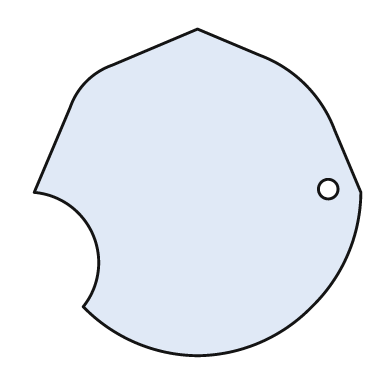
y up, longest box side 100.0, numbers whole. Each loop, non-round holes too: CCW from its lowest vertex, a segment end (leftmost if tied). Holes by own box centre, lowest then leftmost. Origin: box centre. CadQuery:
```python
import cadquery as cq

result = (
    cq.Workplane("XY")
    .moveTo(0.0, -50.0)
    .threePointArc((19.0, -46.0), (35.0, -35.0))
    .threePointArc((46.0, -19.0), (50.0, 0.0))
    .lineTo(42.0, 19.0)
    .threePointArc((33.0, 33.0), (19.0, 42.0))
    .lineTo(0.0, 50.0)
    .lineTo(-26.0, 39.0)
    .threePointArc((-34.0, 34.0), (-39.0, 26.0))
    .lineTo(-50.0, 0.0)
    .threePointArc((-32.0, -13.0), (-35.0, -35.0))
    .threePointArc((-19.0, -46.0), (0.0, -50.0))
    .close()
    .moveTo(40.0, 1.0)
    .circle(3.0)
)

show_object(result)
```